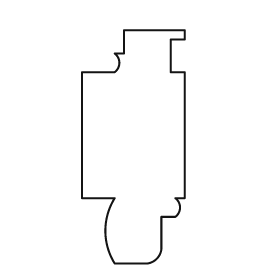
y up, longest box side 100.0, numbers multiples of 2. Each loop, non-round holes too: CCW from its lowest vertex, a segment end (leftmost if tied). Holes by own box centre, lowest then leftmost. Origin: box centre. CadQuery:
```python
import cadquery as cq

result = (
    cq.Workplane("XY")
    .moveTo(-8.0, -50.0)
    .lineTo(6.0, -50.0)
    .threePointArc((10.0, -48.0), (12.0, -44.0))
    .lineTo(12.0, -30.0)
    .lineTo(18.0, -30.0)
    .threePointArc((20.0, -26.0), (18.0, -22.0))
    .lineTo(22.0, -22.0)
    .lineTo(22.0, 32.0)
    .lineTo(16.0, 32.0)
    .lineTo(16.0, 46.0)
    .lineTo(22.0, 46.0)
    .lineTo(22.0, 50.0)
    .lineTo(-4.0, 50.0)
    .lineTo(-4.0, 40.0)
    .lineTo(-8.0, 40.0)
    .threePointArc((-6.0, 36.0), (-8.0, 32.0))
    .lineTo(-22.0, 32.0)
    .lineTo(-22.0, -22.0)
    .lineTo(-8.0, -22.0)
    .threePointArc((-12.0, -36.0), (-8.0, -50.0))
    .close()
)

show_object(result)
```